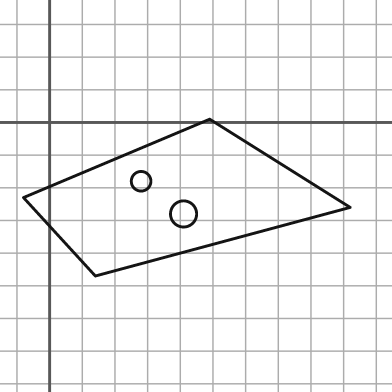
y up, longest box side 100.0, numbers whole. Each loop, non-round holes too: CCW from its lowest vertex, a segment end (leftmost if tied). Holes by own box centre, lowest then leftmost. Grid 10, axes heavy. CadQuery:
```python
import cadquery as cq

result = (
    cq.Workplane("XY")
    .moveTo(14.0, -47.0)
    .lineTo(92.0, -26.0)
    .lineTo(49.0, 1.0)
    .lineTo(-8.0, -23.0)
    .close()
    .moveTo(41.0, -28.0)
    .circle(4.0)
    .moveTo(28.0, -18.0)
    .circle(3.0)
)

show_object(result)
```